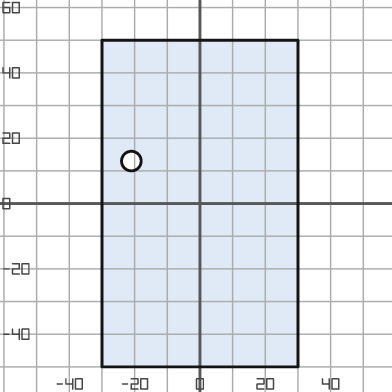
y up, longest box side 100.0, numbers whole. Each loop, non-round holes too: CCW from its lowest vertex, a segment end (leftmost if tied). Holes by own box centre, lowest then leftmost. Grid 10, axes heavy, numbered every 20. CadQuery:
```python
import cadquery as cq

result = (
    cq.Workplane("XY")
    .moveTo(-30.0, -50.0)
    .lineTo(30.0, -50.0)
    .lineTo(30.0, 50.0)
    .lineTo(-30.0, 50.0)
    .close()
    .moveTo(-21.0, 13.0)
    .circle(3.0)
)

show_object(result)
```